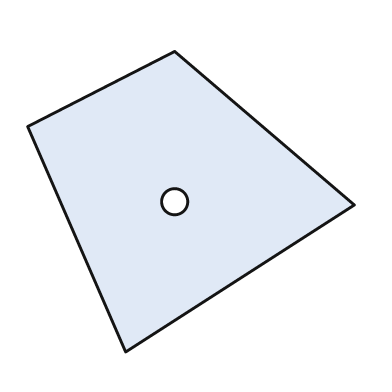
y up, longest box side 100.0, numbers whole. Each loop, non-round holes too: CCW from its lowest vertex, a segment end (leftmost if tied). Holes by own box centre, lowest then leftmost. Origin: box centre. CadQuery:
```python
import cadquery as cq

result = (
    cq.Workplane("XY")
    .moveTo(-20.0, -46.0)
    .lineTo(50.0, -1.0)
    .lineTo(-5.0, 46.0)
    .lineTo(-50.0, 23.0)
    .close()
    .moveTo(-5.0, 0.0)
    .circle(4.0)
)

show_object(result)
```